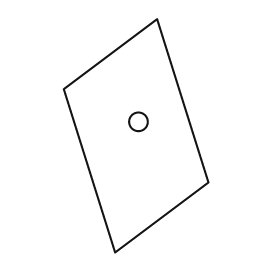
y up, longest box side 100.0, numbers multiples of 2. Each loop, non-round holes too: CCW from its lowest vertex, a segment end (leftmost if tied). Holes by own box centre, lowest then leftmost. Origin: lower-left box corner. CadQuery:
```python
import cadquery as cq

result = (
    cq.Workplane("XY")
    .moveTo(22.0, 0.0)
    .lineTo(62.0, 30.0)
    .lineTo(40.0, 100.0)
    .lineTo(0.0, 70.0)
    .close()
    .moveTo(32.0, 56.0)
    .circle(4.0)
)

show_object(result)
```